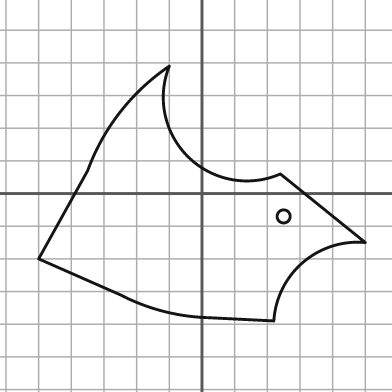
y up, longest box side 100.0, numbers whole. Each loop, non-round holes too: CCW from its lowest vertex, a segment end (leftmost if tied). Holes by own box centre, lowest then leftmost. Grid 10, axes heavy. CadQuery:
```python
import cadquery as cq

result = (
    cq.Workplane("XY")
    .moveTo(22.0, -39.0)
    .threePointArc((31.0, -21.0), (50.0, -15.0))
    .lineTo(24.0, 6.0)
    .threePointArc((-4.0, 11.0), (-10.0, 39.0))
    .threePointArc((-25.0, 25.0), (-35.0, 7.0))
    .lineTo(-50.0, -20.0)
    .lineTo(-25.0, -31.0)
    .threePointArc((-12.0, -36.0), (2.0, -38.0))
    .close()
    .moveTo(25.0, -7.0)
    .circle(2.0)
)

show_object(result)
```